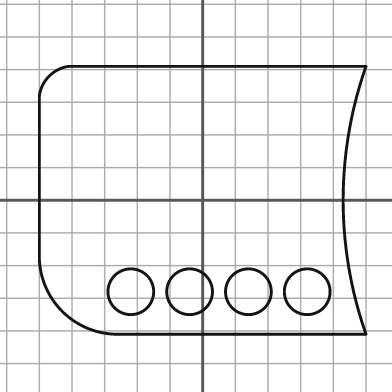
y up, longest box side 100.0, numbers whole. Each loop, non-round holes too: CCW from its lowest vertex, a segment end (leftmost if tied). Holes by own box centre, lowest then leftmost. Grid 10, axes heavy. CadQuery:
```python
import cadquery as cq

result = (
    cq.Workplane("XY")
    .moveTo(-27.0, -41.0)
    .lineTo(50.0, -41.0)
    .threePointArc((43.0, 0.0), (50.0, 41.0))
    .lineTo(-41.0, 41.0)
    .threePointArc((-47.0, 38.0), (-50.0, 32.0))
    .lineTo(-50.0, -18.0)
    .threePointArc((-43.0, -34.0), (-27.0, -41.0))
    .close()
    .moveTo(-22.0, -28.0)
    .circle(7.0)
    .moveTo(-4.0, -28.0)
    .circle(7.0)
    .moveTo(14.0, -28.0)
    .circle(7.0)
    .moveTo(32.0, -28.0)
    .circle(7.0)
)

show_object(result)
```